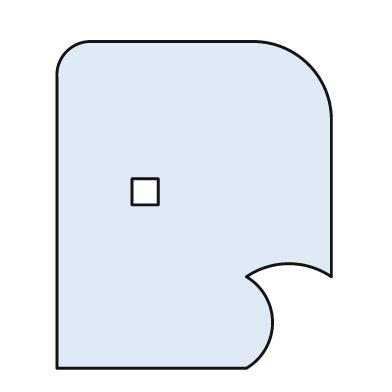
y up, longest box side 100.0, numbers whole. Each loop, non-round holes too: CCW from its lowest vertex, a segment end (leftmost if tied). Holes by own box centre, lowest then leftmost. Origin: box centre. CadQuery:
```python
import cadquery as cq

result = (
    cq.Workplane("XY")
    .moveTo(-42.0, -50.0)
    .lineTo(16.0, -50.0)
    .threePointArc((24.0, -36.0), (16.0, -22.0))
    .threePointArc((29.0, -18.0), (42.0, -22.0))
    .lineTo(42.0, 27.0)
    .threePointArc((35.0, 43.0), (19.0, 50.0))
    .lineTo(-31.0, 50.0)
    .threePointArc((-39.0, 47.0), (-42.0, 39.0))
    .close()
    .moveTo(-19.0, 0.0)
    .lineTo(-11.0, 0.0)
    .lineTo(-11.0, 8.0)
    .lineTo(-19.0, 8.0)
    .close()
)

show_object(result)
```